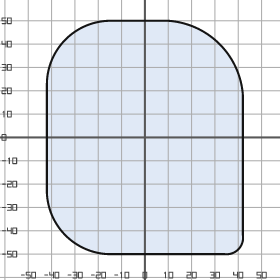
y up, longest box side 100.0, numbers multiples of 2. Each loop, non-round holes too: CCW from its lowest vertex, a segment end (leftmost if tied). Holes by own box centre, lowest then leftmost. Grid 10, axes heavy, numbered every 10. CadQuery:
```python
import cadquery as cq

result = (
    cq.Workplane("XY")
    .moveTo(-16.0, -50.0)
    .lineTo(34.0, -50.0)
    .threePointArc((40.0, -48.0), (42.0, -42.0))
    .lineTo(42.0, 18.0)
    .threePointArc((32.0, 40.0), (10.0, 50.0))
    .lineTo(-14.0, 50.0)
    .threePointArc((-34.0, 42.0), (-42.0, 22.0))
    .lineTo(-42.0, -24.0)
    .threePointArc((-34.0, -42.0), (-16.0, -50.0))
    .close()
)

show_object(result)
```